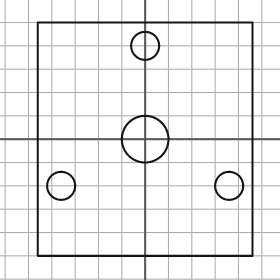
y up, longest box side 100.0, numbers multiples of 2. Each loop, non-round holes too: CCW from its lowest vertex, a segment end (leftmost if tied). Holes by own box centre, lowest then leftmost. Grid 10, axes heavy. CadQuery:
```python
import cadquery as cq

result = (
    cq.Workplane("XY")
    .moveTo(-46.0, -50.0)
    .lineTo(46.0, -50.0)
    .lineTo(46.0, 50.0)
    .lineTo(-46.0, 50.0)
    .close()
    .moveTo(-36.0, -20.0)
    .circle(6.0)
    .moveTo(36.0, -20.0)
    .circle(6.0)
    .moveTo(0.0, 0.0)
    .circle(10.0)
    .moveTo(0.0, 40.0)
    .circle(6.0)
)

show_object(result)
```